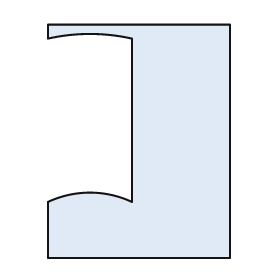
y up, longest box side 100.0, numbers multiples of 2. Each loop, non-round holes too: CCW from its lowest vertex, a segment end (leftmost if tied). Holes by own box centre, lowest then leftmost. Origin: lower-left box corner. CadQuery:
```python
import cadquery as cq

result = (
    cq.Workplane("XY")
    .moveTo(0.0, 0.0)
    .lineTo(78.0, 0.0)
    .lineTo(78.0, 100.0)
    .lineTo(0.0, 100.0)
    .lineTo(0.0, 94.0)
    .threePointArc((18.0, 96.0), (36.0, 94.0))
    .lineTo(36.0, 24.0)
    .threePointArc((18.0, 28.0), (0.0, 24.0))
    .close()
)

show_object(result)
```